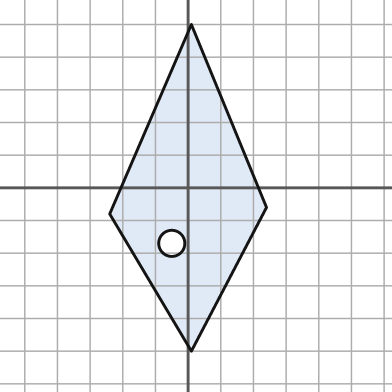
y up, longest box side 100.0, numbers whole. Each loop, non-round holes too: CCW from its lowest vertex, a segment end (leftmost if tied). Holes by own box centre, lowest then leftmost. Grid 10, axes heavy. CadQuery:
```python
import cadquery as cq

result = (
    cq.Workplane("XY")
    .moveTo(1.0, -50.0)
    .lineTo(24.0, -6.0)
    .lineTo(1.0, 50.0)
    .lineTo(-24.0, -8.0)
    .close()
    .moveTo(-5.0, -17.0)
    .circle(4.0)
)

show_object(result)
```